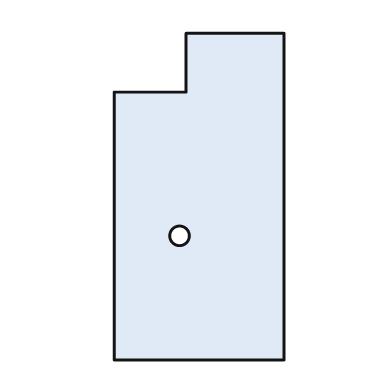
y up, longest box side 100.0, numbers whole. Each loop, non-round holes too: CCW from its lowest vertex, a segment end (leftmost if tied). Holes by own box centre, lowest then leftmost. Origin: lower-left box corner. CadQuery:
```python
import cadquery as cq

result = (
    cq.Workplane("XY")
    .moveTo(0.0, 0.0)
    .lineTo(52.0, 0.0)
    .lineTo(52.0, 100.0)
    .lineTo(22.0, 100.0)
    .lineTo(22.0, 82.0)
    .lineTo(0.0, 82.0)
    .close()
    .moveTo(20.0, 38.0)
    .circle(3.0)
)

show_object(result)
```